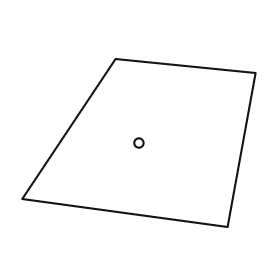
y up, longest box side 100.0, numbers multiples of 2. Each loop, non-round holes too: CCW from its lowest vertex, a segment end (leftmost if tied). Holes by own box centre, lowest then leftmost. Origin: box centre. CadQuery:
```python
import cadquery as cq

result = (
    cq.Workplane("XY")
    .moveTo(38.0, -36.0)
    .lineTo(50.0, 30.0)
    .lineTo(-10.0, 36.0)
    .lineTo(-50.0, -24.0)
    .close()
    .moveTo(0.0, 0.0)
    .circle(2.0)
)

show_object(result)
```